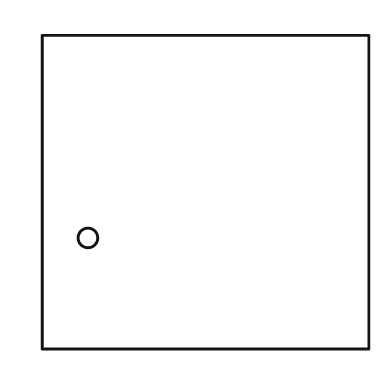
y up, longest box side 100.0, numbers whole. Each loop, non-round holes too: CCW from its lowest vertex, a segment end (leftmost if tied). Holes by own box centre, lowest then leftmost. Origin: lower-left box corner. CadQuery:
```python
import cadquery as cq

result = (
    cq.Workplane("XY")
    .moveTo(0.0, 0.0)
    .lineTo(100.0, 0.0)
    .lineTo(100.0, 96.0)
    .lineTo(0.0, 96.0)
    .close()
    .moveTo(14.0, 34.0)
    .circle(3.0)
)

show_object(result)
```